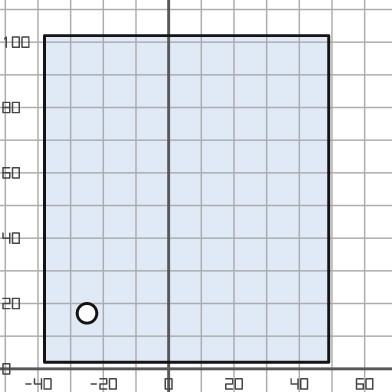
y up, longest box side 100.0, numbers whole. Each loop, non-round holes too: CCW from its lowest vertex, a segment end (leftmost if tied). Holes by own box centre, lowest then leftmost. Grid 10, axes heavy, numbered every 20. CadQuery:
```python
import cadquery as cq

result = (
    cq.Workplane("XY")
    .moveTo(-38.0, 2.0)
    .lineTo(49.0, 2.0)
    .lineTo(49.0, 102.0)
    .lineTo(-38.0, 102.0)
    .close()
    .moveTo(-25.0, 17.0)
    .circle(3.0)
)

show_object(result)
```